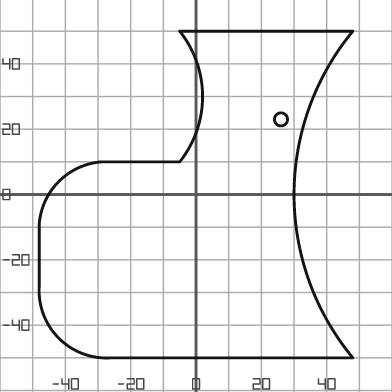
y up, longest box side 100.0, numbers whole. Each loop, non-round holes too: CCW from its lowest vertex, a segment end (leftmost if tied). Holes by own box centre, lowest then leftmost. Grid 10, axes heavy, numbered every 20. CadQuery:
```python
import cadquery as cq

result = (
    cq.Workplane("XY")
    .moveTo(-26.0, -50.0)
    .lineTo(48.0, -50.0)
    .threePointArc((30.0, 0.0), (48.0, 50.0))
    .lineTo(-5.0, 50.0)
    .threePointArc((2.0, 30.0), (-5.0, 10.0))
    .lineTo(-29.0, 10.0)
    .threePointArc((-42.0, 4.0), (-48.0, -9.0))
    .lineTo(-48.0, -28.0)
    .threePointArc((-42.0, -44.0), (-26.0, -50.0))
    .close()
    .moveTo(26.0, 23.0)
    .circle(2.0)
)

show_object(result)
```